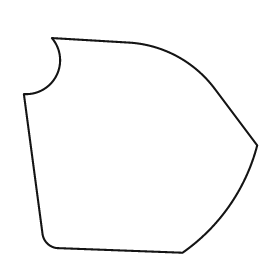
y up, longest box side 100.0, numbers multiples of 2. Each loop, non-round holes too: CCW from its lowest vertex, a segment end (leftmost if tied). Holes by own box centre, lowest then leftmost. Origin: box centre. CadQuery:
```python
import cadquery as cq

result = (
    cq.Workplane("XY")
    .moveTo(18.0, -46.0)
    .threePointArc((38.0, -26.0), (50.0, 0.0))
    .lineTo(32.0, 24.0)
    .threePointArc((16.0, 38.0), (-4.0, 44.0))
    .lineTo(-38.0, 46.0)
    .threePointArc((-36.0, 30.0), (-50.0, 22.0))
    .lineTo(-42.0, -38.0)
    .threePointArc((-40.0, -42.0), (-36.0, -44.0))
    .close()
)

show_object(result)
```